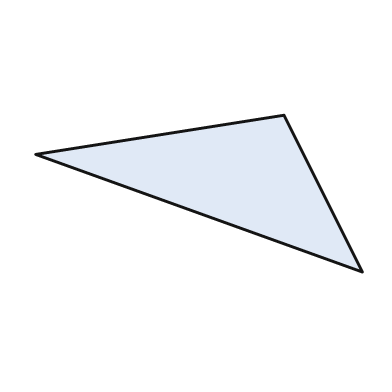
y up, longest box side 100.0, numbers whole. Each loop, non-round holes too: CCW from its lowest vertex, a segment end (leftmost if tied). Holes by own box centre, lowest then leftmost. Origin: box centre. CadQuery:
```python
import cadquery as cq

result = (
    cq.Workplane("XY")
    .moveTo(50.0, -24.0)
    .lineTo(26.0, 24.0)
    .lineTo(-50.0, 12.0)
    .close()
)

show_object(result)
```